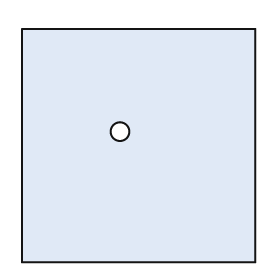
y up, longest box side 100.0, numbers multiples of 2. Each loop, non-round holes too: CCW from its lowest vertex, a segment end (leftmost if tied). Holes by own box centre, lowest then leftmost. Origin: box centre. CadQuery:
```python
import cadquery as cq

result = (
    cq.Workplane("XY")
    .moveTo(-50.0, -50.0)
    .lineTo(50.0, -50.0)
    .lineTo(50.0, 50.0)
    .lineTo(-50.0, 50.0)
    .close()
    .moveTo(-8.0, 6.0)
    .circle(4.0)
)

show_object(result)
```